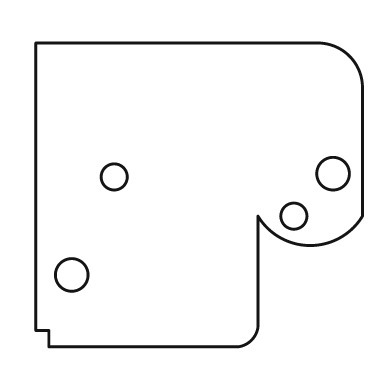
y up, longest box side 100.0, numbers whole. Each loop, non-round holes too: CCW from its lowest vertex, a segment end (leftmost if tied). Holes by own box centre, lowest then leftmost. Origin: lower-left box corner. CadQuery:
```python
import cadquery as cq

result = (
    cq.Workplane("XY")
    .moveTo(4.0, 0.0)
    .lineTo(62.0, 0.0)
    .threePointArc((66.0, 2.0), (68.0, 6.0))
    .lineTo(68.0, 40.0)
    .threePointArc((84.0, 31.0), (100.0, 40.0))
    .lineTo(100.0, 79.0)
    .threePointArc((96.0, 89.0), (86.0, 93.0))
    .lineTo(0.0, 93.0)
    .lineTo(0.0, 5.0)
    .lineTo(4.0, 5.0)
    .close()
    .moveTo(11.0, 22.0)
    .circle(5.0)
    .moveTo(79.0, 40.0)
    .circle(4.0)
    .moveTo(24.0, 52.0)
    .circle(4.0)
    .moveTo(91.0, 53.0)
    .circle(5.0)
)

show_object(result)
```